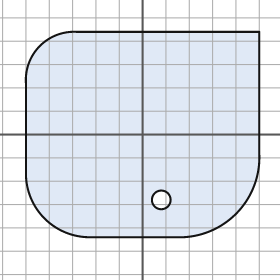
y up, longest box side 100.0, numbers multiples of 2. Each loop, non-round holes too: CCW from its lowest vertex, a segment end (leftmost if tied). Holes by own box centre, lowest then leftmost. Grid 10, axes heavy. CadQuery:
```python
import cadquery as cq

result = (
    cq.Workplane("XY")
    .moveTo(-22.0, -44.0)
    .lineTo(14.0, -44.0)
    .threePointArc((40.0, -34.0), (50.0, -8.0))
    .lineTo(50.0, 44.0)
    .lineTo(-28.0, 44.0)
    .threePointArc((-44.0, 38.0), (-50.0, 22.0))
    .lineTo(-50.0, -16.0)
    .threePointArc((-42.0, -36.0), (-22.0, -44.0))
    .close()
    .moveTo(8.0, -28.0)
    .circle(4.0)
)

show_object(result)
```